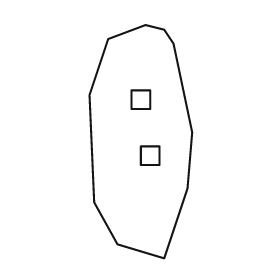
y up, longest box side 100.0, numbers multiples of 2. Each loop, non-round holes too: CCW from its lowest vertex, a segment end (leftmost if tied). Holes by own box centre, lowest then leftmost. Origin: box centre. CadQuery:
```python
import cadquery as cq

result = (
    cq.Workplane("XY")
    .moveTo(10.0, -50.0)
    .lineTo(20.0, -20.0)
    .lineTo(22.0, 4.0)
    .lineTo(14.0, 42.0)
    .lineTo(10.0, 48.0)
    .lineTo(2.0, 50.0)
    .lineTo(-14.0, 44.0)
    .lineTo(-22.0, 20.0)
    .lineTo(-20.0, -26.0)
    .lineTo(-10.0, -44.0)
    .close()
    .moveTo(0.0, -10.0)
    .lineTo(8.0, -10.0)
    .lineTo(8.0, -2.0)
    .lineTo(0.0, -2.0)
    .close()
    .moveTo(-4.0, 14.0)
    .lineTo(4.0, 14.0)
    .lineTo(4.0, 22.0)
    .lineTo(-4.0, 22.0)
    .close()
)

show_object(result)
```